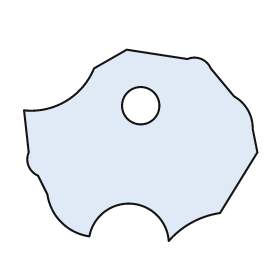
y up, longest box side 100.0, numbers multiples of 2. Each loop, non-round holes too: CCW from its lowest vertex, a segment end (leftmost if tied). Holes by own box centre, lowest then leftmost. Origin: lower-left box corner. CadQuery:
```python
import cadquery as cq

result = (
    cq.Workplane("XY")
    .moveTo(62.0, 0.0)
    .threePointArc((72.0, 8.0), (84.0, 12.0))
    .lineTo(100.0, 38.0)
    .lineTo(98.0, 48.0)
    .threePointArc((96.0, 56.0), (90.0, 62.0))
    .lineTo(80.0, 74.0)
    .threePointArc((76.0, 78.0), (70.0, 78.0))
    .lineTo(44.0, 82.0)
    .lineTo(30.0, 74.0)
    .threePointArc((18.0, 60.0), (0.0, 56.0))
    .lineTo(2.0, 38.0)
    .threePointArc((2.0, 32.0), (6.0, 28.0))
    .lineTo(10.0, 20.0)
    .threePointArc((16.0, 8.0), (28.0, 2.0))
    .threePointArc((46.0, 16.0), (62.0, 0.0))
    .close()
    .moveTo(50.0, 58.0)
    .circle(8.0)
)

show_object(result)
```